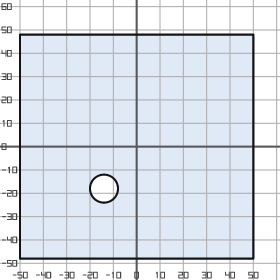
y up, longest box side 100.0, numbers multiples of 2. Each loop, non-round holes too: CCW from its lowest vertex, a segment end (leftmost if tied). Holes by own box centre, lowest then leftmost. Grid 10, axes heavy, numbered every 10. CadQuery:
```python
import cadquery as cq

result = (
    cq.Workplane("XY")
    .moveTo(-50.0, -48.0)
    .lineTo(50.0, -48.0)
    .lineTo(50.0, 48.0)
    .lineTo(-50.0, 48.0)
    .close()
    .moveTo(-14.0, -18.0)
    .circle(6.0)
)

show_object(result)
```